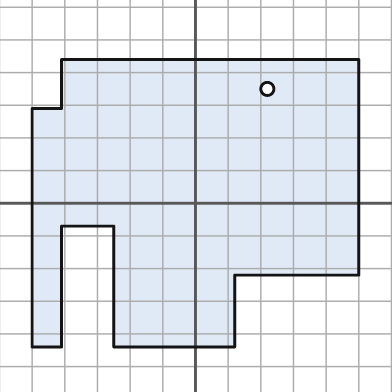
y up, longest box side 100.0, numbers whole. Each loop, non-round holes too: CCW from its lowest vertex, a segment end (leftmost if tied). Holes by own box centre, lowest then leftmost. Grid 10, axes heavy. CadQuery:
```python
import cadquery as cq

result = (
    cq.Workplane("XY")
    .moveTo(-50.0, -44.0)
    .lineTo(-41.0, -44.0)
    .lineTo(-41.0, -7.0)
    .lineTo(-25.0, -7.0)
    .lineTo(-25.0, -44.0)
    .lineTo(12.0, -44.0)
    .lineTo(12.0, -22.0)
    .lineTo(50.0, -22.0)
    .lineTo(50.0, 44.0)
    .lineTo(-41.0, 44.0)
    .lineTo(-41.0, 29.0)
    .lineTo(-50.0, 29.0)
    .close()
    .moveTo(22.0, 35.0)
    .circle(2.0)
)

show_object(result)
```